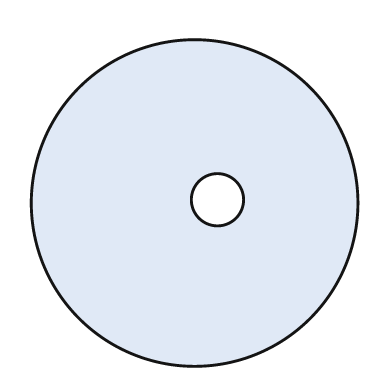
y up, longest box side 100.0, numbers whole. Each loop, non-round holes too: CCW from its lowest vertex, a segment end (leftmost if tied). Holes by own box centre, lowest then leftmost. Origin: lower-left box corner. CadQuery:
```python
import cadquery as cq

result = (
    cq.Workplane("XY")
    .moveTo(50.0, 50.0)
    .circle(50.0)
    .moveTo(57.0, 51.0)
    .circle(8.0)
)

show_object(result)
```